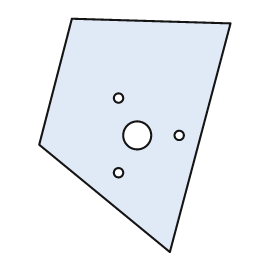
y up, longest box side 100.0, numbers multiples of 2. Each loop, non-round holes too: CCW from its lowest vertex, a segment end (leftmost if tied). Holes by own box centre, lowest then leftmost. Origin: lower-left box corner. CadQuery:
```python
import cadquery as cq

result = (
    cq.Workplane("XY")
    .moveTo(56.0, 0.0)
    .lineTo(82.0, 98.0)
    .lineTo(14.0, 100.0)
    .lineTo(0.0, 46.0)
    .close()
    .moveTo(34.0, 34.0)
    .circle(2.0)
    .moveTo(42.0, 50.0)
    .circle(6.0)
    .moveTo(60.0, 50.0)
    .circle(2.0)
    .moveTo(34.0, 66.0)
    .circle(2.0)
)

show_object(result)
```